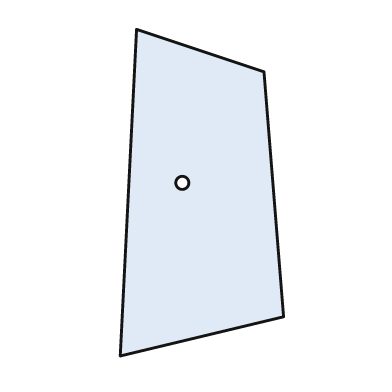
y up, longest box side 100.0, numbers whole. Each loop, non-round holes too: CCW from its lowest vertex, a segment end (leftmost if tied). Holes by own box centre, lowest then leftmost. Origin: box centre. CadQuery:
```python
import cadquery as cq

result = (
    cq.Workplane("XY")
    .moveTo(-25.0, -50.0)
    .lineTo(25.0, -38.0)
    .lineTo(19.0, 37.0)
    .lineTo(-20.0, 50.0)
    .close()
    .moveTo(-6.0, 3.0)
    .circle(2.0)
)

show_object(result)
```